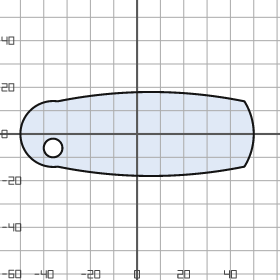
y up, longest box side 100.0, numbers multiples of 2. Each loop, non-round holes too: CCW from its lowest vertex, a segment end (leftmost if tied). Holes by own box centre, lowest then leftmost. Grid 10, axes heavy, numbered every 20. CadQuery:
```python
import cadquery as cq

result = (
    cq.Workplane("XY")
    .moveTo(-34.0, -14.0)
    .threePointArc((6.0, -18.0), (46.0, -14.0))
    .threePointArc((50.0, 0.0), (46.0, 14.0))
    .threePointArc((6.0, 18.0), (-34.0, 14.0))
    .threePointArc((-50.0, 0.0), (-34.0, -14.0))
    .close()
    .moveTo(-36.0, -6.0)
    .circle(4.0)
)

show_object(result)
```